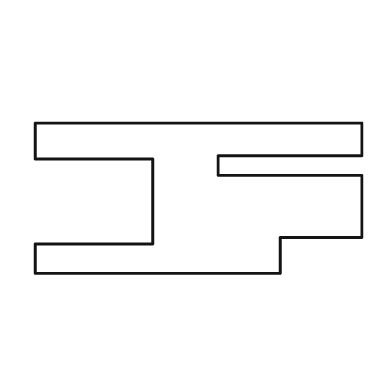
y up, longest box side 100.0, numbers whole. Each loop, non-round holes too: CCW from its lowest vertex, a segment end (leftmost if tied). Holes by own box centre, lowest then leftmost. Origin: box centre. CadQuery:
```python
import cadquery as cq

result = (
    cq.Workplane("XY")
    .moveTo(-50.0, -23.0)
    .lineTo(25.0, -23.0)
    .lineTo(25.0, -12.0)
    .lineTo(50.0, -12.0)
    .lineTo(50.0, 7.0)
    .lineTo(6.0, 7.0)
    .lineTo(6.0, 13.0)
    .lineTo(50.0, 13.0)
    .lineTo(50.0, 23.0)
    .lineTo(-50.0, 23.0)
    .lineTo(-50.0, 12.0)
    .lineTo(-14.0, 12.0)
    .lineTo(-14.0, -14.0)
    .lineTo(-50.0, -14.0)
    .close()
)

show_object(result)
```